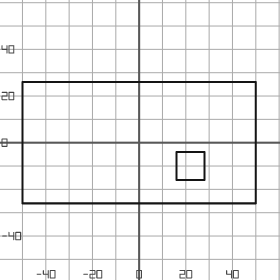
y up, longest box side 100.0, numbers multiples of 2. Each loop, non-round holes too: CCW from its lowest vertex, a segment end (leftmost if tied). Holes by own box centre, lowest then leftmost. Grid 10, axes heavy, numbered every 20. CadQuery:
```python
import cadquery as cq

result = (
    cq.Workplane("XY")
    .moveTo(-50.0, -26.0)
    .lineTo(50.0, -26.0)
    .lineTo(50.0, 26.0)
    .lineTo(-50.0, 26.0)
    .close()
    .moveTo(16.0, -16.0)
    .lineTo(28.0, -16.0)
    .lineTo(28.0, -4.0)
    .lineTo(16.0, -4.0)
    .close()
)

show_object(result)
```